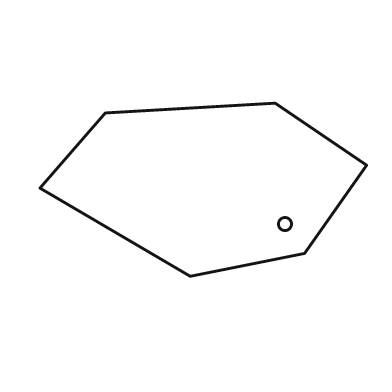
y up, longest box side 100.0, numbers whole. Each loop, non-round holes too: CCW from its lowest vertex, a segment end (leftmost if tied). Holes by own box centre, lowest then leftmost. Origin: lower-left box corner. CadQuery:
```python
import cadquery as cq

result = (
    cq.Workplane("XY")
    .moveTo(46.0, 0.0)
    .lineTo(81.0, 7.0)
    .lineTo(100.0, 34.0)
    .lineTo(72.0, 53.0)
    .lineTo(20.0, 50.0)
    .lineTo(0.0, 27.0)
    .close()
    .moveTo(75.0, 16.0)
    .circle(2.0)
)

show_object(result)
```